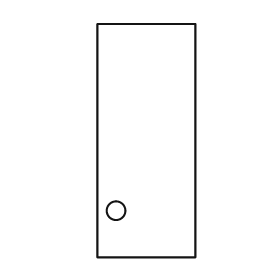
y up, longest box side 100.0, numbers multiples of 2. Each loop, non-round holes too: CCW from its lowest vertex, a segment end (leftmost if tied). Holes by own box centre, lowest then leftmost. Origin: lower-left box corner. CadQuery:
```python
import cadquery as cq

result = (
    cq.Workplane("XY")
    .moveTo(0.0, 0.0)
    .lineTo(42.0, 0.0)
    .lineTo(42.0, 100.0)
    .lineTo(0.0, 100.0)
    .close()
    .moveTo(8.0, 20.0)
    .circle(4.0)
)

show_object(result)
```